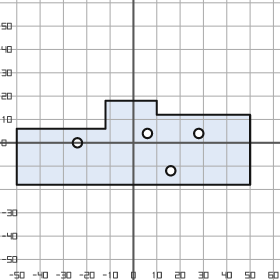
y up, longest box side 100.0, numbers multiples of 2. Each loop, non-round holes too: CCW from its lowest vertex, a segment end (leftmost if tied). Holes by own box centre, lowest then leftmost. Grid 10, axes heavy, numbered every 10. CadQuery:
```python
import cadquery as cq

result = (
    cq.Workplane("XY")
    .moveTo(-50.0, -18.0)
    .lineTo(50.0, -18.0)
    .lineTo(50.0, 12.0)
    .lineTo(10.0, 12.0)
    .lineTo(10.0, 18.0)
    .lineTo(-12.0, 18.0)
    .lineTo(-12.0, 6.0)
    .lineTo(-50.0, 6.0)
    .close()
    .moveTo(16.0, -12.0)
    .circle(2.0)
    .moveTo(-24.0, 0.0)
    .circle(2.0)
    .moveTo(6.0, 4.0)
    .circle(2.0)
    .moveTo(28.0, 4.0)
    .circle(2.0)
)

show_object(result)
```